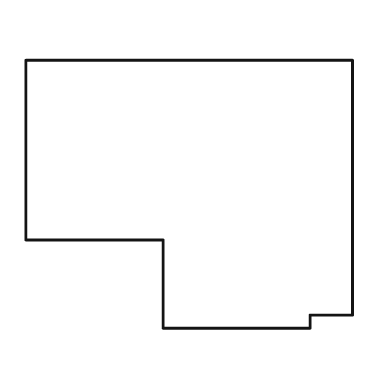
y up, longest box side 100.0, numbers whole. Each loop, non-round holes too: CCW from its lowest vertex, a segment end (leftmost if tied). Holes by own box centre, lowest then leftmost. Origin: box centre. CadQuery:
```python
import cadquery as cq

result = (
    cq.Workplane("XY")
    .moveTo(-8.0, -41.0)
    .lineTo(37.0, -41.0)
    .lineTo(37.0, -37.0)
    .lineTo(50.0, -37.0)
    .lineTo(50.0, 41.0)
    .lineTo(-50.0, 41.0)
    .lineTo(-50.0, -14.0)
    .lineTo(-8.0, -14.0)
    .close()
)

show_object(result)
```